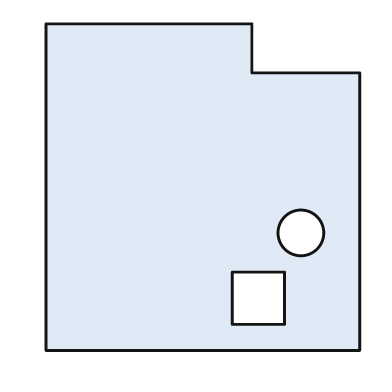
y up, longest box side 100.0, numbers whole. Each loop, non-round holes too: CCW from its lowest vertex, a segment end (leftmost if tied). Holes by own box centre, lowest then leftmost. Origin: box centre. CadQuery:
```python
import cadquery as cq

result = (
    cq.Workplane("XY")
    .moveTo(-48.0, -50.0)
    .lineTo(48.0, -50.0)
    .lineTo(48.0, 35.0)
    .lineTo(15.0, 35.0)
    .lineTo(15.0, 50.0)
    .lineTo(-48.0, 50.0)
    .close()
    .moveTo(9.0, -42.0)
    .lineTo(25.0, -42.0)
    .lineTo(25.0, -26.0)
    .lineTo(9.0, -26.0)
    .close()
    .moveTo(30.0, -14.0)
    .circle(7.0)
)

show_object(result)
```